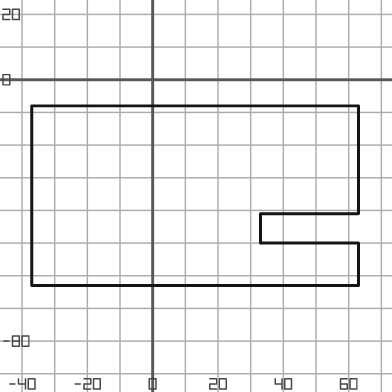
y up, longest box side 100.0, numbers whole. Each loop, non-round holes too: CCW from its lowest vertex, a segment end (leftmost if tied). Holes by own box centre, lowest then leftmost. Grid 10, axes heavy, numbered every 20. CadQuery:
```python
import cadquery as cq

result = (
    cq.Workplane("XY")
    .moveTo(-37.0, -63.0)
    .lineTo(63.0, -63.0)
    .lineTo(63.0, -50.0)
    .lineTo(33.0, -50.0)
    .lineTo(33.0, -41.0)
    .lineTo(63.0, -41.0)
    .lineTo(63.0, -8.0)
    .lineTo(-37.0, -8.0)
    .close()
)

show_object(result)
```